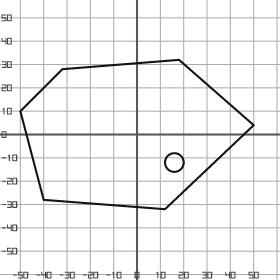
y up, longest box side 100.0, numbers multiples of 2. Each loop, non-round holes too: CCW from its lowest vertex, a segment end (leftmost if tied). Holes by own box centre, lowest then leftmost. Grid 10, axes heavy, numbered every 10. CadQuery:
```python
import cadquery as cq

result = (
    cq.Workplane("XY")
    .moveTo(12.0, -32.0)
    .lineTo(50.0, 4.0)
    .lineTo(18.0, 32.0)
    .lineTo(-32.0, 28.0)
    .lineTo(-50.0, 10.0)
    .lineTo(-40.0, -28.0)
    .close()
    .moveTo(16.0, -12.0)
    .circle(4.0)
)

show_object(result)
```